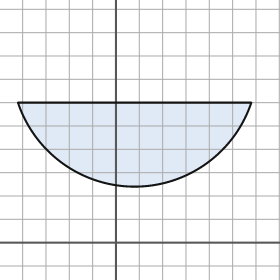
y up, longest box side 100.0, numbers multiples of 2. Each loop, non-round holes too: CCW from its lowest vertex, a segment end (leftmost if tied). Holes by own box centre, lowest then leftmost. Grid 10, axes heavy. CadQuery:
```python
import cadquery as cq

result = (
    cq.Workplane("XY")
    .moveTo(-42.0, 60.0)
    .threePointArc((8.0, 24.0), (58.0, 60.0))
    .close()
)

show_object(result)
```